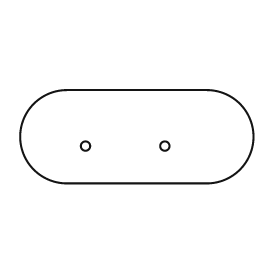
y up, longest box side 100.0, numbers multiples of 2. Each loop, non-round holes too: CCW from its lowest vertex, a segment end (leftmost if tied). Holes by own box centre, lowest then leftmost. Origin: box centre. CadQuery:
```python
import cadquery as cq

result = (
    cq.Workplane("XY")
    .moveTo(-30.0, -20.0)
    .lineTo(30.0, -20.0)
    .threePointArc((50.0, 0.0), (30.0, 20.0))
    .lineTo(-30.0, 20.0)
    .threePointArc((-50.0, 0.0), (-30.0, -20.0))
    .close()
    .moveTo(-22.0, -4.0)
    .circle(2.0)
    .moveTo(12.0, -4.0)
    .circle(2.0)
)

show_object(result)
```